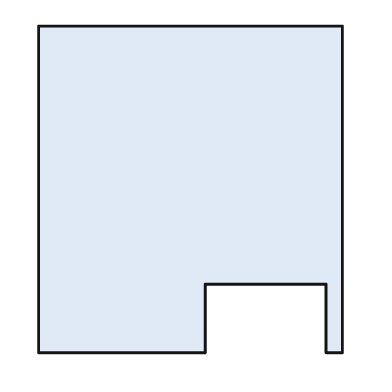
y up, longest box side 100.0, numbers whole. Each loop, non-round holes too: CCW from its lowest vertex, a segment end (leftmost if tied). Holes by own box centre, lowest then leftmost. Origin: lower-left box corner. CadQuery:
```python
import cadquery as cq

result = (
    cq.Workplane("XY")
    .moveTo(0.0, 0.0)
    .lineTo(51.0, 0.0)
    .lineTo(51.0, 21.0)
    .lineTo(88.0, 21.0)
    .lineTo(88.0, 0.0)
    .lineTo(93.0, 0.0)
    .lineTo(93.0, 100.0)
    .lineTo(0.0, 100.0)
    .close()
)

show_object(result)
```